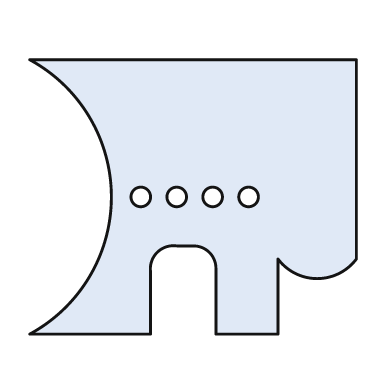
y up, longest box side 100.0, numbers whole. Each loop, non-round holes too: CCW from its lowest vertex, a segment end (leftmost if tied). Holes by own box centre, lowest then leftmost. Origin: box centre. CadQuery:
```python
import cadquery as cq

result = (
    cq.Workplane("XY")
    .moveTo(-50.0, -42.0)
    .lineTo(-13.0, -42.0)
    .lineTo(-13.0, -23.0)
    .threePointArc((-11.0, -17.0), (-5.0, -15.0))
    .lineTo(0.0, -15.0)
    .threePointArc((5.0, -17.0), (7.0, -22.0))
    .lineTo(7.0, -42.0)
    .lineTo(26.0, -42.0)
    .lineTo(26.0, -19.0)
    .threePointArc((38.0, -25.0), (50.0, -19.0))
    .lineTo(50.0, 42.0)
    .lineTo(-50.0, 42.0)
    .threePointArc((-25.0, 0.0), (-50.0, -42.0))
    .close()
    .moveTo(-16.0, 0.0)
    .circle(3.0)
    .moveTo(-5.0, 0.0)
    .circle(3.0)
    .moveTo(6.0, 0.0)
    .circle(3.0)
    .moveTo(17.0, 0.0)
    .circle(3.0)
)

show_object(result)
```